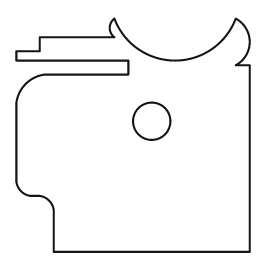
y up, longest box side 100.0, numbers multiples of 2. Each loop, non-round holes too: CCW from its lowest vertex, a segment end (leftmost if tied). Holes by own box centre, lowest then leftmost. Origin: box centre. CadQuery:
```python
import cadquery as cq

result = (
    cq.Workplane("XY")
    .moveTo(-34.0, -50.0)
    .lineTo(50.0, -50.0)
    .lineTo(50.0, 30.0)
    .lineTo(44.0, 30.0)
    .threePointArc((50.0, 40.0), (44.0, 50.0))
    .threePointArc((18.0, 32.0), (-8.0, 50.0))
    .threePointArc((-10.0, 46.0), (-8.0, 42.0))
    .lineTo(-40.0, 42.0)
    .lineTo(-40.0, 36.0)
    .lineTo(-50.0, 36.0)
    .lineTo(-50.0, 32.0)
    .lineTo(-2.0, 32.0)
    .lineTo(-2.0, 26.0)
    .lineTo(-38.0, 26.0)
    .threePointArc((-46.0, 22.0), (-50.0, 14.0))
    .lineTo(-50.0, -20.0)
    .threePointArc((-48.0, -24.0), (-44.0, -26.0))
    .lineTo(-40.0, -26.0)
    .threePointArc((-36.0, -28.0), (-34.0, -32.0))
    .close()
    .moveTo(8.0, 6.0)
    .circle(8.0)
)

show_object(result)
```